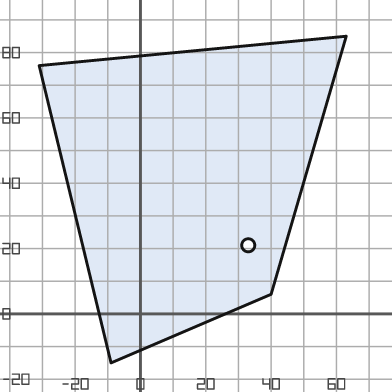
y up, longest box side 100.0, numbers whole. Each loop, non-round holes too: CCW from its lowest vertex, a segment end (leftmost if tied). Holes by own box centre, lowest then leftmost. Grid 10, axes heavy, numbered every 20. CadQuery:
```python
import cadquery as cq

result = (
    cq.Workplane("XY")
    .moveTo(-9.0, -15.0)
    .lineTo(40.0, 6.0)
    .lineTo(63.0, 85.0)
    .lineTo(-31.0, 76.0)
    .close()
    .moveTo(33.0, 21.0)
    .circle(2.0)
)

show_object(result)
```